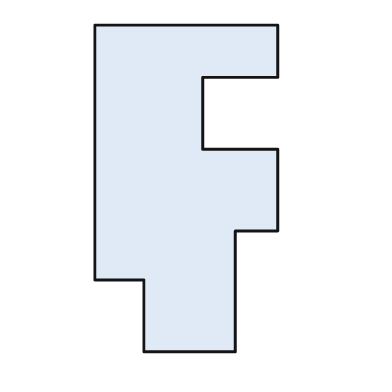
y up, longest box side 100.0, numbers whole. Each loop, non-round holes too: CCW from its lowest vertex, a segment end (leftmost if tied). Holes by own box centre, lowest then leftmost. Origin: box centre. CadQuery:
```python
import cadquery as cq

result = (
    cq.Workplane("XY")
    .moveTo(-13.0, -50.0)
    .lineTo(15.0, -50.0)
    .lineTo(15.0, -13.0)
    .lineTo(28.0, -13.0)
    .lineTo(28.0, 12.0)
    .lineTo(5.0, 12.0)
    .lineTo(5.0, 34.0)
    .lineTo(28.0, 34.0)
    .lineTo(28.0, 50.0)
    .lineTo(-28.0, 50.0)
    .lineTo(-28.0, -28.0)
    .lineTo(-13.0, -28.0)
    .close()
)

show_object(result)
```